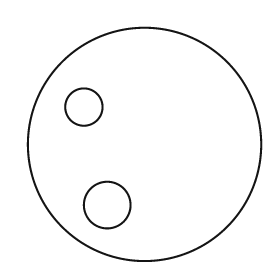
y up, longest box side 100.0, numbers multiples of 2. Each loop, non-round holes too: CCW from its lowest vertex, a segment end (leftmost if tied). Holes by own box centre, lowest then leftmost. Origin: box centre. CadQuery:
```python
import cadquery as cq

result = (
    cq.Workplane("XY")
    .moveTo(0.0, 0.0)
    .circle(50.0)
    .moveTo(-16.0, -26.0)
    .circle(10.0)
    .moveTo(-26.0, 16.0)
    .circle(8.0)
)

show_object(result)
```